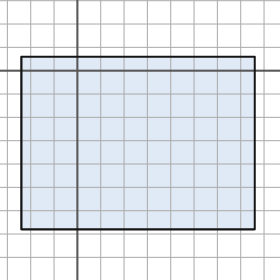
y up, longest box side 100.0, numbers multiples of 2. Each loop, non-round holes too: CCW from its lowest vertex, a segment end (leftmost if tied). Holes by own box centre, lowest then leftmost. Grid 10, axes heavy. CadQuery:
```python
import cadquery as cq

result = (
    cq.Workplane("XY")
    .moveTo(-24.0, -68.0)
    .lineTo(76.0, -68.0)
    .lineTo(76.0, 6.0)
    .lineTo(-24.0, 6.0)
    .close()
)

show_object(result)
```